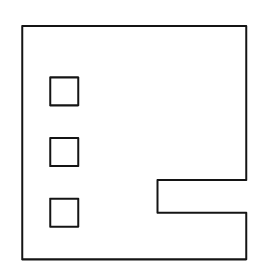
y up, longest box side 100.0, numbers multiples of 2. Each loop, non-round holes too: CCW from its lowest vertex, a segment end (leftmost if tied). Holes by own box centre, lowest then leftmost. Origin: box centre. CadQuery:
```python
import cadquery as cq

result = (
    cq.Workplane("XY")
    .moveTo(-48.0, -50.0)
    .lineTo(48.0, -50.0)
    .lineTo(48.0, -30.0)
    .lineTo(10.0, -30.0)
    .lineTo(10.0, -16.0)
    .lineTo(48.0, -16.0)
    .lineTo(48.0, 50.0)
    .lineTo(-48.0, 50.0)
    .close()
    .moveTo(-36.0, -36.0)
    .lineTo(-24.0, -36.0)
    .lineTo(-24.0, -24.0)
    .lineTo(-36.0, -24.0)
    .close()
    .moveTo(-36.0, -10.0)
    .lineTo(-24.0, -10.0)
    .lineTo(-24.0, 2.0)
    .lineTo(-36.0, 2.0)
    .close()
    .moveTo(-36.0, 16.0)
    .lineTo(-24.0, 16.0)
    .lineTo(-24.0, 28.0)
    .lineTo(-36.0, 28.0)
    .close()
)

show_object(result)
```